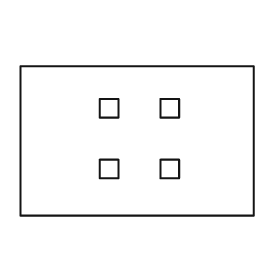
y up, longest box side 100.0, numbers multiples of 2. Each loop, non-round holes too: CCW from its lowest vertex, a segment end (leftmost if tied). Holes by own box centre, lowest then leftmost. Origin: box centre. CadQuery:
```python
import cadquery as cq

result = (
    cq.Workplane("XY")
    .moveTo(-50.0, -32.0)
    .lineTo(50.0, -32.0)
    .lineTo(50.0, 32.0)
    .lineTo(-50.0, 32.0)
    .close()
    .moveTo(-16.0, -16.0)
    .lineTo(-8.0, -16.0)
    .lineTo(-8.0, -8.0)
    .lineTo(-16.0, -8.0)
    .close()
    .moveTo(10.0, -16.0)
    .lineTo(18.0, -16.0)
    .lineTo(18.0, -8.0)
    .lineTo(10.0, -8.0)
    .close()
    .moveTo(-16.0, 10.0)
    .lineTo(-8.0, 10.0)
    .lineTo(-8.0, 18.0)
    .lineTo(-16.0, 18.0)
    .close()
    .moveTo(10.0, 10.0)
    .lineTo(18.0, 10.0)
    .lineTo(18.0, 18.0)
    .lineTo(10.0, 18.0)
    .close()
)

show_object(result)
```